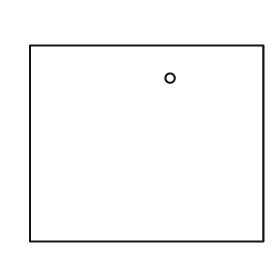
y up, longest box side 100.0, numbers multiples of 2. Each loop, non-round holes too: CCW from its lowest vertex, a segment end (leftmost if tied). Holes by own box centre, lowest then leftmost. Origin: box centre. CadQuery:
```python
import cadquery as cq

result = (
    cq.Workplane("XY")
    .moveTo(-50.0, -42.0)
    .lineTo(50.0, -42.0)
    .lineTo(50.0, 42.0)
    .lineTo(-50.0, 42.0)
    .close()
    .moveTo(10.0, 28.0)
    .circle(2.0)
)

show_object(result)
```